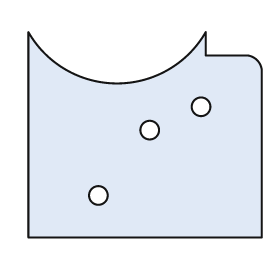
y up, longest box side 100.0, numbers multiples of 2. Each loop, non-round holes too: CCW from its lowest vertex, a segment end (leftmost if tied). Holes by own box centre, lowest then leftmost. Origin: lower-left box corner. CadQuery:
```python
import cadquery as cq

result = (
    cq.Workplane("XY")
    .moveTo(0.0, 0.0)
    .lineTo(100.0, 0.0)
    .lineTo(100.0, 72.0)
    .threePointArc((98.0, 76.0), (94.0, 78.0))
    .lineTo(76.0, 78.0)
    .lineTo(76.0, 88.0)
    .threePointArc((38.0, 66.0), (0.0, 88.0))
    .close()
    .moveTo(30.0, 18.0)
    .circle(4.0)
    .moveTo(52.0, 46.0)
    .circle(4.0)
    .moveTo(74.0, 56.0)
    .circle(4.0)
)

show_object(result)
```